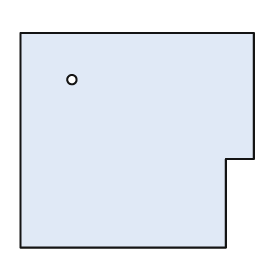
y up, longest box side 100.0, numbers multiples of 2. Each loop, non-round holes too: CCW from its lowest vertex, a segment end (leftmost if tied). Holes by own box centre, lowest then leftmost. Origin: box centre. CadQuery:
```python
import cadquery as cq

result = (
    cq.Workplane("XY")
    .moveTo(-50.0, -46.0)
    .lineTo(38.0, -46.0)
    .lineTo(38.0, -8.0)
    .lineTo(50.0, -8.0)
    .lineTo(50.0, 46.0)
    .lineTo(-50.0, 46.0)
    .close()
    .moveTo(-28.0, 26.0)
    .circle(2.0)
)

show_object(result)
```